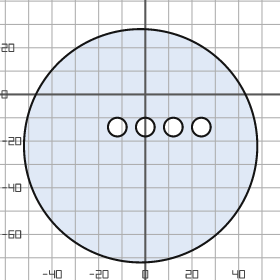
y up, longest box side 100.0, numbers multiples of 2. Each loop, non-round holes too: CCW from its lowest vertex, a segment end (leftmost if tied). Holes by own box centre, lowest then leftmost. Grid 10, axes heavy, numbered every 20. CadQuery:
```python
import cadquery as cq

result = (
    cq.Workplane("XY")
    .moveTo(-2.0, -22.0)
    .circle(50.0)
    .moveTo(-12.0, -14.0)
    .circle(4.0)
    .moveTo(0.0, -14.0)
    .circle(4.0)
    .moveTo(12.0, -14.0)
    .circle(4.0)
    .moveTo(24.0, -14.0)
    .circle(4.0)
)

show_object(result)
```